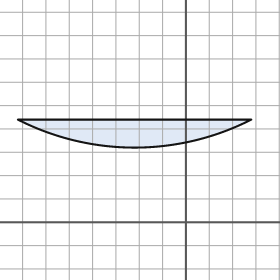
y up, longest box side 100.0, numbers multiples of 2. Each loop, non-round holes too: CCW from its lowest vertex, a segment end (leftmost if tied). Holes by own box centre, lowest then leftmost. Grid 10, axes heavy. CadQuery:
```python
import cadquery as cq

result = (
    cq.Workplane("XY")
    .moveTo(-72.0, 44.0)
    .threePointArc((-22.0, 32.0), (28.0, 44.0))
    .close()
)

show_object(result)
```